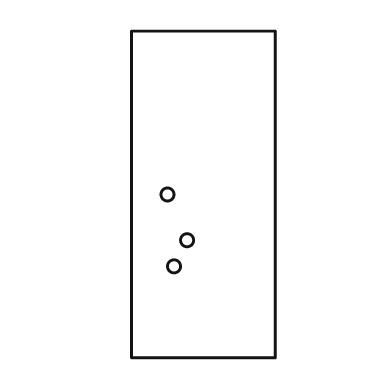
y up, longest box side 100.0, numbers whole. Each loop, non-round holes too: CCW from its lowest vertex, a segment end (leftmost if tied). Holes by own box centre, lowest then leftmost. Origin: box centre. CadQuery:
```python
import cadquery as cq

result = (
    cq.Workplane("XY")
    .moveTo(-22.0, -50.0)
    .lineTo(22.0, -50.0)
    .lineTo(22.0, 50.0)
    .lineTo(-22.0, 50.0)
    .close()
    .moveTo(-9.0, -22.0)
    .circle(2.0)
    .moveTo(-5.0, -14.0)
    .circle(2.0)
    .moveTo(-11.0, 0.0)
    .circle(2.0)
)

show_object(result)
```